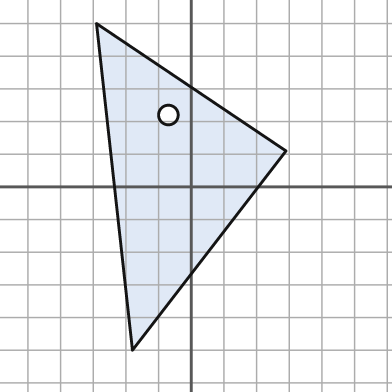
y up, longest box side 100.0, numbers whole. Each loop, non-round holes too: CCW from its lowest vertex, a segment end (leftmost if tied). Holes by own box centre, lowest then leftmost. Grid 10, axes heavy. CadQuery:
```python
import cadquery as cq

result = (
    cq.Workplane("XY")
    .moveTo(-18.0, -50.0)
    .lineTo(29.0, 11.0)
    .lineTo(-29.0, 50.0)
    .close()
    .moveTo(-7.0, 22.0)
    .circle(3.0)
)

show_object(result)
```